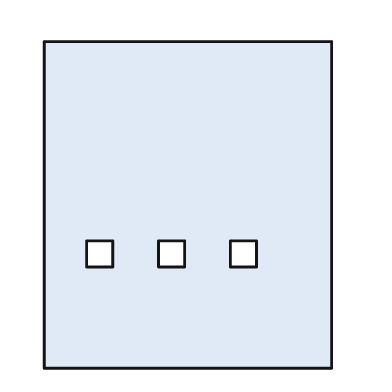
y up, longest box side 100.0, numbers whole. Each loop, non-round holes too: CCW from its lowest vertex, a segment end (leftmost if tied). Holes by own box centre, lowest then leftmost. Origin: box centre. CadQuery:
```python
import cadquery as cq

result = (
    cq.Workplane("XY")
    .moveTo(-44.0, -50.0)
    .lineTo(44.0, -50.0)
    .lineTo(44.0, 50.0)
    .lineTo(-44.0, 50.0)
    .close()
    .moveTo(-31.0, -19.0)
    .lineTo(-23.0, -19.0)
    .lineTo(-23.0, -11.0)
    .lineTo(-31.0, -11.0)
    .close()
    .moveTo(-9.0, -19.0)
    .lineTo(-1.0, -19.0)
    .lineTo(-1.0, -11.0)
    .lineTo(-9.0, -11.0)
    .close()
    .moveTo(13.0, -19.0)
    .lineTo(21.0, -19.0)
    .lineTo(21.0, -11.0)
    .lineTo(13.0, -11.0)
    .close()
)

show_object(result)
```